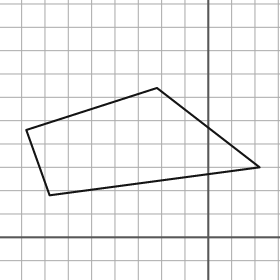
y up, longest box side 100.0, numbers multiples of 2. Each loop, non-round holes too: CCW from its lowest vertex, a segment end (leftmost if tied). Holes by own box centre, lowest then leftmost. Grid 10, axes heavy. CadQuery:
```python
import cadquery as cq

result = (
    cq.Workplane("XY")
    .moveTo(-68.0, 18.0)
    .lineTo(22.0, 30.0)
    .lineTo(-22.0, 64.0)
    .lineTo(-78.0, 46.0)
    .close()
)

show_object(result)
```